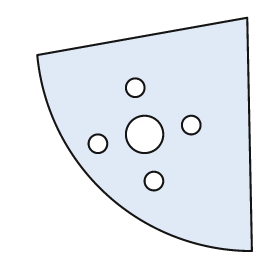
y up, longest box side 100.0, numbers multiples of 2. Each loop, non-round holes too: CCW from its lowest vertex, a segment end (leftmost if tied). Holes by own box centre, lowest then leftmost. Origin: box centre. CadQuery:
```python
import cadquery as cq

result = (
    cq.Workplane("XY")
    .moveTo(46.0, -50.0)
    .lineTo(44.0, 50.0)
    .lineTo(-46.0, 34.0)
    .threePointArc((-16.0, -26.0), (46.0, -50.0))
    .close()
    .moveTo(4.0, -20.0)
    .circle(4.0)
    .moveTo(-20.0, -4.0)
    .circle(4.0)
    .moveTo(0.0, 0.0)
    .circle(8.0)
    .moveTo(20.0, 4.0)
    .circle(4.0)
    .moveTo(-4.0, 20.0)
    .circle(4.0)
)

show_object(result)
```